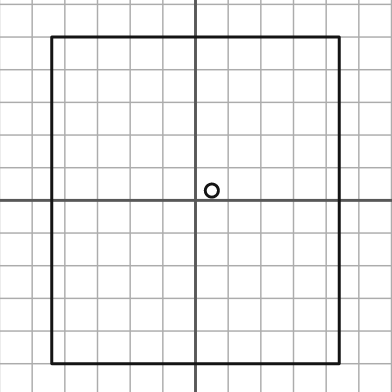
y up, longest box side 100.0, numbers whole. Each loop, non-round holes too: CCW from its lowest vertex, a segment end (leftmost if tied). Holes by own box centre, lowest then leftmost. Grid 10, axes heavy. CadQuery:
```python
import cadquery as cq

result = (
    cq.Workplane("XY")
    .moveTo(-44.0, -50.0)
    .lineTo(44.0, -50.0)
    .lineTo(44.0, 50.0)
    .lineTo(-44.0, 50.0)
    .close()
    .moveTo(5.0, 3.0)
    .circle(2.0)
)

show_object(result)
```